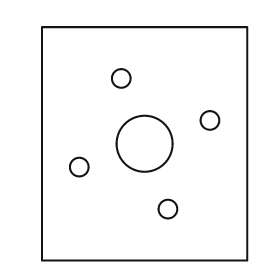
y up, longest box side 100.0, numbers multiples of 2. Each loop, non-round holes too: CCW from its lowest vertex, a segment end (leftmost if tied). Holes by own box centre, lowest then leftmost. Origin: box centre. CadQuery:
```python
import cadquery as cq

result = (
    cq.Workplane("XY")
    .moveTo(-44.0, -50.0)
    .lineTo(44.0, -50.0)
    .lineTo(44.0, 50.0)
    .lineTo(-44.0, 50.0)
    .close()
    .moveTo(10.0, -28.0)
    .circle(4.0)
    .moveTo(-28.0, -10.0)
    .circle(4.0)
    .moveTo(0.0, 0.0)
    .circle(12.0)
    .moveTo(28.0, 10.0)
    .circle(4.0)
    .moveTo(-10.0, 28.0)
    .circle(4.0)
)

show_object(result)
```